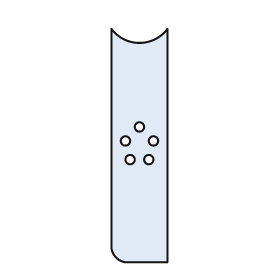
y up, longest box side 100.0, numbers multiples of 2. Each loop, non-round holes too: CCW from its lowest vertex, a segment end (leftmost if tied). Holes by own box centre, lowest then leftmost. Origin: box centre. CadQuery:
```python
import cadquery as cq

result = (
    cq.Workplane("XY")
    .moveTo(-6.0, -50.0)
    .lineTo(12.0, -50.0)
    .lineTo(12.0, 50.0)
    .threePointArc((0.0, 44.0), (-12.0, 50.0))
    .lineTo(-12.0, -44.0)
    .threePointArc((-10.0, -48.0), (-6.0, -50.0))
    .close()
    .moveTo(-4.0, -6.0)
    .circle(2.0)
    .moveTo(4.0, -6.0)
    .circle(2.0)
    .moveTo(-6.0, 2.0)
    .circle(2.0)
    .moveTo(6.0, 2.0)
    .circle(2.0)
    .moveTo(0.0, 8.0)
    .circle(2.0)
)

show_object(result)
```